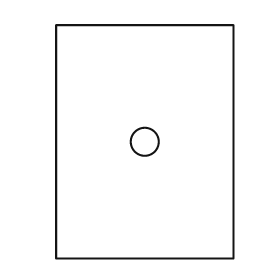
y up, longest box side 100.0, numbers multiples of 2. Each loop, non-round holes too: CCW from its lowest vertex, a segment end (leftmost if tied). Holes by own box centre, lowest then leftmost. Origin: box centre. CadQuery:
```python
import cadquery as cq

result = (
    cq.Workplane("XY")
    .moveTo(-38.0, -50.0)
    .lineTo(38.0, -50.0)
    .lineTo(38.0, 50.0)
    .lineTo(-38.0, 50.0)
    .close()
    .moveTo(0.0, 0.0)
    .circle(6.0)
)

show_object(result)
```